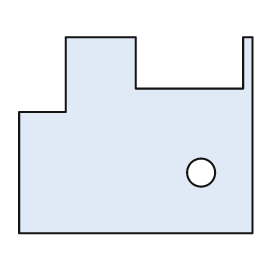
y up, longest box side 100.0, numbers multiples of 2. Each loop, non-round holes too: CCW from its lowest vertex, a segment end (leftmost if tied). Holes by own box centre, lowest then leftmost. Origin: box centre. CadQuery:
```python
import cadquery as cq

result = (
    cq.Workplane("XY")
    .moveTo(-50.0, -42.0)
    .lineTo(50.0, -42.0)
    .lineTo(50.0, 42.0)
    .lineTo(46.0, 42.0)
    .lineTo(46.0, 20.0)
    .lineTo(0.0, 20.0)
    .lineTo(0.0, 42.0)
    .lineTo(-30.0, 42.0)
    .lineTo(-30.0, 10.0)
    .lineTo(-50.0, 10.0)
    .close()
    .moveTo(28.0, -16.0)
    .circle(6.0)
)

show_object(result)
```